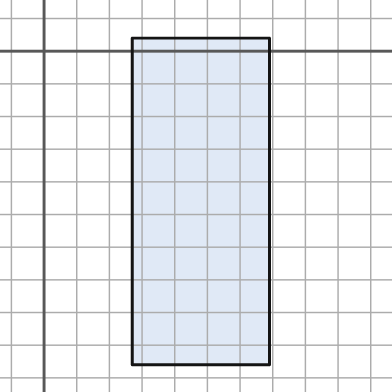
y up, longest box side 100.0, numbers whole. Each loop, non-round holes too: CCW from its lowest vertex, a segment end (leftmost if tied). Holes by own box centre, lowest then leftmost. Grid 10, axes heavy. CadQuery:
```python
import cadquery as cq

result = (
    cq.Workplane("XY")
    .moveTo(27.0, -96.0)
    .lineTo(69.0, -96.0)
    .lineTo(69.0, 4.0)
    .lineTo(27.0, 4.0)
    .close()
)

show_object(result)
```